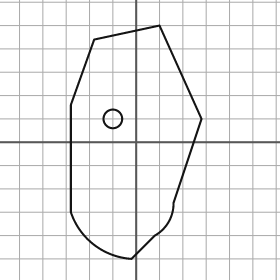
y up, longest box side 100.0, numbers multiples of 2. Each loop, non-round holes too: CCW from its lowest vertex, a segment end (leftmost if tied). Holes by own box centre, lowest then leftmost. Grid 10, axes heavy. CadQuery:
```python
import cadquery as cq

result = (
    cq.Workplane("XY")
    .moveTo(-2.0, -50.0)
    .lineTo(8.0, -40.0)
    .threePointArc((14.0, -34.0), (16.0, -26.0))
    .lineTo(28.0, 10.0)
    .lineTo(10.0, 50.0)
    .lineTo(-18.0, 44.0)
    .lineTo(-28.0, 16.0)
    .lineTo(-28.0, -30.0)
    .threePointArc((-18.0, -44.0), (-2.0, -50.0))
    .close()
    .moveTo(-10.0, 10.0)
    .circle(4.0)
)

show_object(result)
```